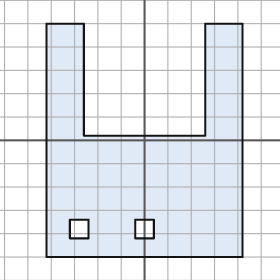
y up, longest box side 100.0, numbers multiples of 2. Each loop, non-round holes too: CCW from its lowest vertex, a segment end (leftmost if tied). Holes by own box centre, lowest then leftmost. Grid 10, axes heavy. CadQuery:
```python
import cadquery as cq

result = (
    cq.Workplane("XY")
    .moveTo(-42.0, -50.0)
    .lineTo(42.0, -50.0)
    .lineTo(42.0, 50.0)
    .lineTo(26.0, 50.0)
    .lineTo(26.0, 2.0)
    .lineTo(-26.0, 2.0)
    .lineTo(-26.0, 50.0)
    .lineTo(-42.0, 50.0)
    .close()
    .moveTo(-32.0, -42.0)
    .lineTo(-24.0, -42.0)
    .lineTo(-24.0, -34.0)
    .lineTo(-32.0, -34.0)
    .close()
    .moveTo(-4.0, -42.0)
    .lineTo(4.0, -42.0)
    .lineTo(4.0, -34.0)
    .lineTo(-4.0, -34.0)
    .close()
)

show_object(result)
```